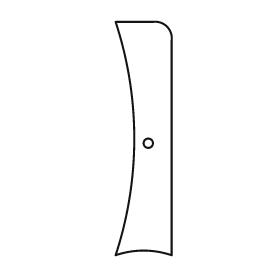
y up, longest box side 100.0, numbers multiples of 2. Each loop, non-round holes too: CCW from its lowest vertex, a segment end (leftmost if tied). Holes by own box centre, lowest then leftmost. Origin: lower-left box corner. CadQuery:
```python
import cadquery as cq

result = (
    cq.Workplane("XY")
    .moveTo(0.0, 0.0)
    .threePointArc((12.0, 2.0), (24.0, 0.0))
    .lineTo(24.0, 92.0)
    .threePointArc((22.0, 98.0), (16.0, 100.0))
    .lineTo(0.0, 100.0)
    .threePointArc((8.0, 50.0), (0.0, 0.0))
    .close()
    .moveTo(14.0, 48.0)
    .circle(2.0)
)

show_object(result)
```